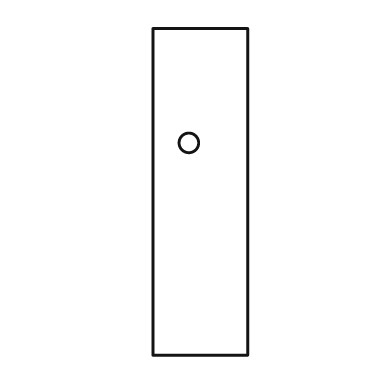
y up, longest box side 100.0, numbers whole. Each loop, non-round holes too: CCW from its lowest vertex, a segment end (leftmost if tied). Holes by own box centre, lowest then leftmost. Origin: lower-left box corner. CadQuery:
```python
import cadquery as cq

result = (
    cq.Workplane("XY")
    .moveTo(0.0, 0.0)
    .lineTo(29.0, 0.0)
    .lineTo(29.0, 100.0)
    .lineTo(0.0, 100.0)
    .close()
    .moveTo(11.0, 65.0)
    .circle(3.0)
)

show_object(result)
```